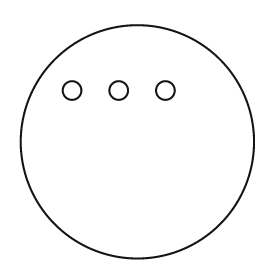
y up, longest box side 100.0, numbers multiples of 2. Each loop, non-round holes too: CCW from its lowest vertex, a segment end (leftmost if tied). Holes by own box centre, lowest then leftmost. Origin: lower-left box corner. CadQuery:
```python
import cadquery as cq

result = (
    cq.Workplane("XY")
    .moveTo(50.0, 50.0)
    .circle(50.0)
    .moveTo(22.0, 72.0)
    .circle(4.0)
    .moveTo(42.0, 72.0)
    .circle(4.0)
    .moveTo(62.0, 72.0)
    .circle(4.0)
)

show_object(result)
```